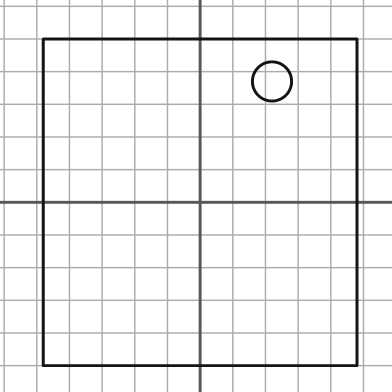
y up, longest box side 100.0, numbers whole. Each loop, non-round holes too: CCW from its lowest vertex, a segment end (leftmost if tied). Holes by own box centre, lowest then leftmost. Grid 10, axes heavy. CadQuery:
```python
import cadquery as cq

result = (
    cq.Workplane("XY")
    .moveTo(-48.0, -50.0)
    .lineTo(48.0, -50.0)
    .lineTo(48.0, 50.0)
    .lineTo(-48.0, 50.0)
    .close()
    .moveTo(22.0, 37.0)
    .circle(6.0)
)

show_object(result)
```